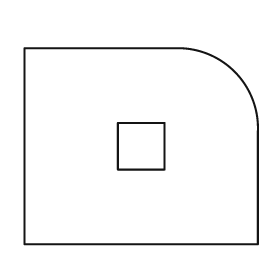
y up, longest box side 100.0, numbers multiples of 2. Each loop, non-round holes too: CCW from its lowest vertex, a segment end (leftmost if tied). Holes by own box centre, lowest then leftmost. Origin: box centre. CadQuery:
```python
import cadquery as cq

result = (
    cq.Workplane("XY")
    .moveTo(-50.0, -42.0)
    .lineTo(50.0, -42.0)
    .lineTo(50.0, 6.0)
    .threePointArc((40.0, 32.0), (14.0, 42.0))
    .lineTo(-50.0, 42.0)
    .close()
    .moveTo(-10.0, -10.0)
    .lineTo(10.0, -10.0)
    .lineTo(10.0, 10.0)
    .lineTo(-10.0, 10.0)
    .close()
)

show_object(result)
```